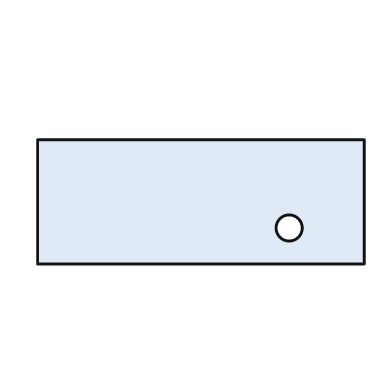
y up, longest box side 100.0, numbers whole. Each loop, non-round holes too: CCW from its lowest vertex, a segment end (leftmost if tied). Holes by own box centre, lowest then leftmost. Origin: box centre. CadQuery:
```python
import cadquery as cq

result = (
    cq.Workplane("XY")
    .moveTo(-50.0, -19.0)
    .lineTo(50.0, -19.0)
    .lineTo(50.0, 19.0)
    .lineTo(-50.0, 19.0)
    .close()
    .moveTo(27.0, -8.0)
    .circle(4.0)
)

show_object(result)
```